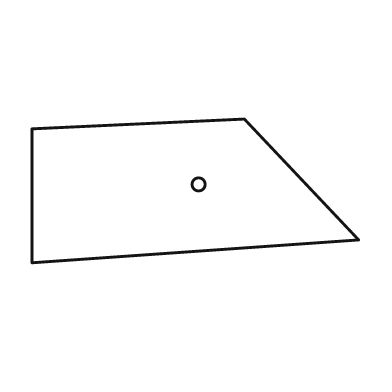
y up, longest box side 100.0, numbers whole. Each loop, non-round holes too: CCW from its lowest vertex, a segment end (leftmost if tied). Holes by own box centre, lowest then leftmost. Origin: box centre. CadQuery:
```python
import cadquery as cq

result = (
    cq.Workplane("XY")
    .moveTo(-50.0, -22.0)
    .lineTo(50.0, -15.0)
    .lineTo(15.0, 22.0)
    .lineTo(-50.0, 19.0)
    .close()
    .moveTo(1.0, 2.0)
    .circle(2.0)
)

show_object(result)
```